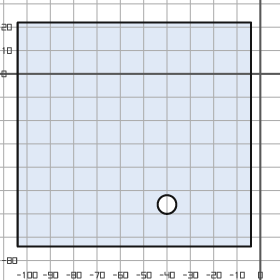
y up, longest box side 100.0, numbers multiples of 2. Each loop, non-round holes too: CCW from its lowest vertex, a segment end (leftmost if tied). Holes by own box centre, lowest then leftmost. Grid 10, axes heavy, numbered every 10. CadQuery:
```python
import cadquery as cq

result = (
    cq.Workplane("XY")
    .moveTo(-104.0, -74.0)
    .lineTo(-4.0, -74.0)
    .lineTo(-4.0, 22.0)
    .lineTo(-104.0, 22.0)
    .close()
    .moveTo(-40.0, -56.0)
    .circle(4.0)
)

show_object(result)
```